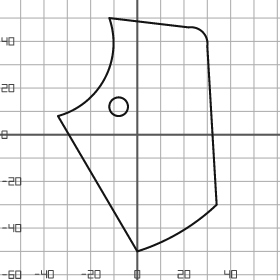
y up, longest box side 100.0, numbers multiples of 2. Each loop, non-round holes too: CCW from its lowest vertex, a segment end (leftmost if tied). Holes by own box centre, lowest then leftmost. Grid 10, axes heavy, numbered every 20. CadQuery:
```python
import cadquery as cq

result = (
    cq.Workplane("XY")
    .moveTo(0.0, -50.0)
    .threePointArc((18.0, -42.0), (34.0, -30.0))
    .lineTo(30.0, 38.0)
    .threePointArc((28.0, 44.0), (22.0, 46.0))
    .lineTo(-12.0, 50.0)
    .threePointArc((-14.0, 24.0), (-34.0, 8.0))
    .close()
    .moveTo(-8.0, 12.0)
    .circle(4.0)
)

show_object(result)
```